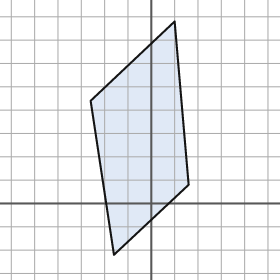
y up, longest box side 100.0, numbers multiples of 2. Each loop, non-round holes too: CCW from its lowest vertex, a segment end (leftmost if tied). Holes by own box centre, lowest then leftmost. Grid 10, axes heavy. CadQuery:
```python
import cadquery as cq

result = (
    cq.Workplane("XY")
    .moveTo(-16.0, -22.0)
    .lineTo(16.0, 8.0)
    .lineTo(10.0, 78.0)
    .lineTo(-26.0, 44.0)
    .close()
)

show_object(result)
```